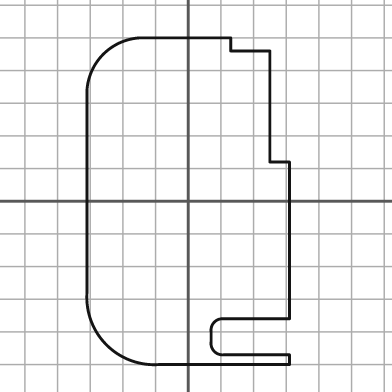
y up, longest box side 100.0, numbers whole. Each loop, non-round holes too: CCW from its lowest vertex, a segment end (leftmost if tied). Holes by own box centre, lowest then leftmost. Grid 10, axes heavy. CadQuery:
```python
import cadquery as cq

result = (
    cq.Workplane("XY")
    .moveTo(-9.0, -50.0)
    .lineTo(31.0, -50.0)
    .lineTo(31.0, -47.0)
    .lineTo(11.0, -47.0)
    .threePointArc((8.0, -46.0), (7.0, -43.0))
    .lineTo(7.0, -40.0)
    .threePointArc((8.0, -37.0), (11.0, -36.0))
    .lineTo(31.0, -36.0)
    .lineTo(31.0, 12.0)
    .lineTo(25.0, 12.0)
    .lineTo(25.0, 46.0)
    .lineTo(13.0, 46.0)
    .lineTo(13.0, 50.0)
    .lineTo(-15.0, 50.0)
    .threePointArc((-26.0, 45.0), (-31.0, 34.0))
    .lineTo(-31.0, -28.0)
    .threePointArc((-25.0, -44.0), (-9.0, -50.0))
    .close()
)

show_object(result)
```